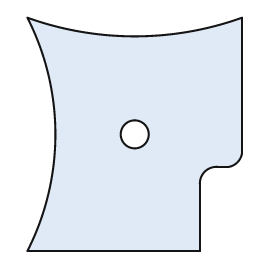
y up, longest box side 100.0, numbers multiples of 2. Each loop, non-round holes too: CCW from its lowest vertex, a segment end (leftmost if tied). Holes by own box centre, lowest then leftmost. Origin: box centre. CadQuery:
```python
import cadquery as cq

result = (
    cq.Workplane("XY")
    .moveTo(-46.0, -50.0)
    .lineTo(28.0, -50.0)
    .lineTo(28.0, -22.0)
    .threePointArc((30.0, -16.0), (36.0, -14.0))
    .lineTo(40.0, -14.0)
    .threePointArc((44.0, -12.0), (46.0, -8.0))
    .lineTo(46.0, 50.0)
    .threePointArc((0.0, 42.0), (-46.0, 50.0))
    .threePointArc((-34.0, 0.0), (-46.0, -50.0))
    .close()
    .moveTo(0.0, 0.0)
    .circle(6.0)
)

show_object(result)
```